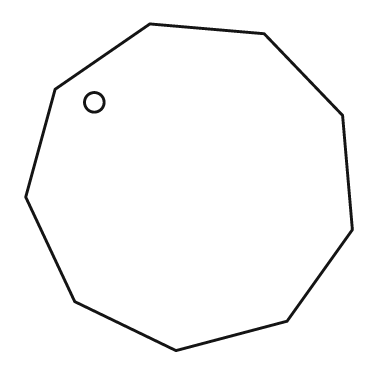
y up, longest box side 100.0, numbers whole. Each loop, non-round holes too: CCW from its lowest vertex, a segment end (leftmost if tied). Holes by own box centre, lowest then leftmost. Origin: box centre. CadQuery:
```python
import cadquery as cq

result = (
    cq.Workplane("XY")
    .moveTo(-4.0, -50.0)
    .lineTo(30.0, -41.0)
    .lineTo(50.0, -13.0)
    .lineTo(47.0, 22.0)
    .lineTo(23.0, 47.0)
    .lineTo(-12.0, 50.0)
    .lineTo(-41.0, 30.0)
    .lineTo(-50.0, -3.0)
    .lineTo(-35.0, -35.0)
    .close()
    .moveTo(-29.0, 26.0)
    .circle(3.0)
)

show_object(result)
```